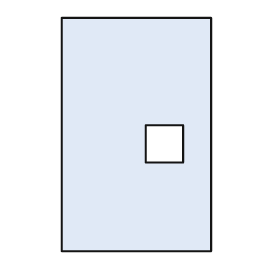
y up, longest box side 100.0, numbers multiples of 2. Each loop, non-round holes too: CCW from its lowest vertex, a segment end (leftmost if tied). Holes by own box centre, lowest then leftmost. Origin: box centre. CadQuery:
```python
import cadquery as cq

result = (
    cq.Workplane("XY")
    .moveTo(-32.0, -50.0)
    .lineTo(32.0, -50.0)
    .lineTo(32.0, 50.0)
    .lineTo(-32.0, 50.0)
    .close()
    .moveTo(4.0, -12.0)
    .lineTo(20.0, -12.0)
    .lineTo(20.0, 4.0)
    .lineTo(4.0, 4.0)
    .close()
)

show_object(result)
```